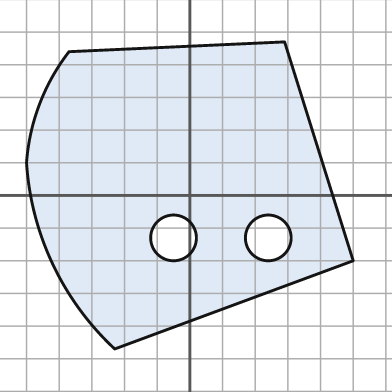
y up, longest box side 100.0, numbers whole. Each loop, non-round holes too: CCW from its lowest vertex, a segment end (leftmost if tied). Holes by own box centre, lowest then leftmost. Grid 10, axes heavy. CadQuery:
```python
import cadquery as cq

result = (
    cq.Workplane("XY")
    .moveTo(-23.0, -47.0)
    .lineTo(50.0, -20.0)
    .lineTo(29.0, 47.0)
    .lineTo(-37.0, 44.0)
    .threePointArc((-46.0, 28.0), (-50.0, 10.0))
    .threePointArc((-42.0, -21.0), (-23.0, -47.0))
    .close()
    .moveTo(-5.0, -13.0)
    .circle(7.0)
    .moveTo(24.0, -13.0)
    .circle(7.0)
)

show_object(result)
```